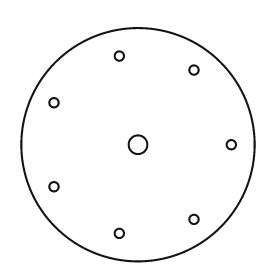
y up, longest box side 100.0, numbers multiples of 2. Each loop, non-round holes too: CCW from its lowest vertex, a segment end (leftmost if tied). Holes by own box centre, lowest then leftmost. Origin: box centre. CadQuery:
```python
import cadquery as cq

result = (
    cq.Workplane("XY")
    .moveTo(0.0, 0.0)
    .circle(50.0)
    .moveTo(-8.0, -38.0)
    .circle(2.0)
    .moveTo(24.0, -32.0)
    .circle(2.0)
    .moveTo(-36.0, -18.0)
    .circle(2.0)
    .moveTo(0.0, 0.0)
    .circle(4.0)
    .moveTo(40.0, 0.0)
    .circle(2.0)
    .moveTo(-36.0, 18.0)
    .circle(2.0)
    .moveTo(24.0, 32.0)
    .circle(2.0)
    .moveTo(-8.0, 38.0)
    .circle(2.0)
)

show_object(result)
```